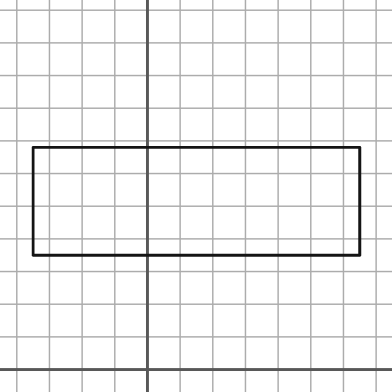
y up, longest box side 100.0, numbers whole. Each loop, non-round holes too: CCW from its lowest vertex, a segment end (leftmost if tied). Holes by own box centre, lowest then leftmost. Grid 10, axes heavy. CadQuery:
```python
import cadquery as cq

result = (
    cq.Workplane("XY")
    .moveTo(-35.0, 35.0)
    .lineTo(65.0, 35.0)
    .lineTo(65.0, 68.0)
    .lineTo(-35.0, 68.0)
    .close()
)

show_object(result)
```